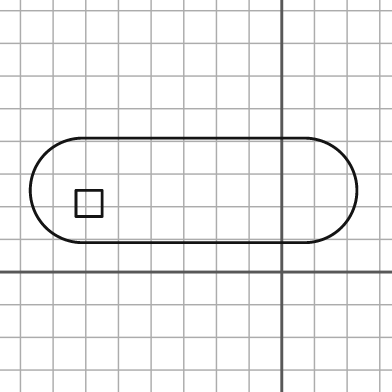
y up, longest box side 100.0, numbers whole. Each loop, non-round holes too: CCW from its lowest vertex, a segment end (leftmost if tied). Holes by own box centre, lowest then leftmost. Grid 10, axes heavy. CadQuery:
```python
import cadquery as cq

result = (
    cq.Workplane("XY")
    .moveTo(-61.0, 9.0)
    .lineTo(7.0, 9.0)
    .threePointArc((23.0, 25.0), (7.0, 41.0))
    .lineTo(-61.0, 41.0)
    .threePointArc((-77.0, 25.0), (-61.0, 9.0))
    .close()
    .moveTo(-63.0, 17.0)
    .lineTo(-55.0, 17.0)
    .lineTo(-55.0, 25.0)
    .lineTo(-63.0, 25.0)
    .close()
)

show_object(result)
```